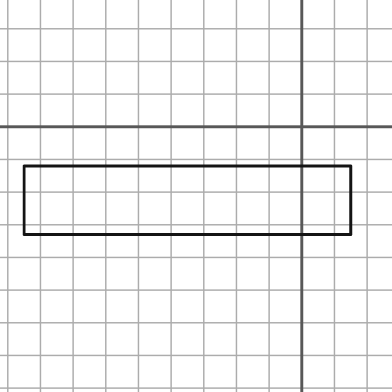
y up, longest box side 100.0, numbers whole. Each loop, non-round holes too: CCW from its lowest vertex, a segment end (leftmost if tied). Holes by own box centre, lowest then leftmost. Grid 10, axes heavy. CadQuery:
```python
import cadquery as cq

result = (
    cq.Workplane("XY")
    .moveTo(-85.0, -33.0)
    .lineTo(15.0, -33.0)
    .lineTo(15.0, -12.0)
    .lineTo(-85.0, -12.0)
    .close()
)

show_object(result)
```